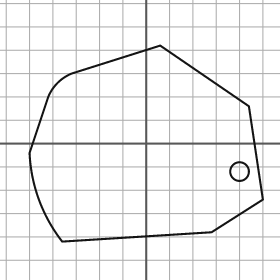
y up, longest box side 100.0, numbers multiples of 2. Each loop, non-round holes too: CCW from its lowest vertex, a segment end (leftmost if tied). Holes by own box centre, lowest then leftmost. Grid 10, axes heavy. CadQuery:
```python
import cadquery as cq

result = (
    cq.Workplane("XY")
    .moveTo(-36.0, -42.0)
    .lineTo(28.0, -38.0)
    .lineTo(50.0, -24.0)
    .lineTo(44.0, 16.0)
    .lineTo(6.0, 42.0)
    .lineTo(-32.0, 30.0)
    .threePointArc((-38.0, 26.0), (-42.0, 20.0))
    .lineTo(-50.0, -4.0)
    .threePointArc((-46.0, -24.0), (-36.0, -42.0))
    .close()
    .moveTo(40.0, -12.0)
    .circle(4.0)
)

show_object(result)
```